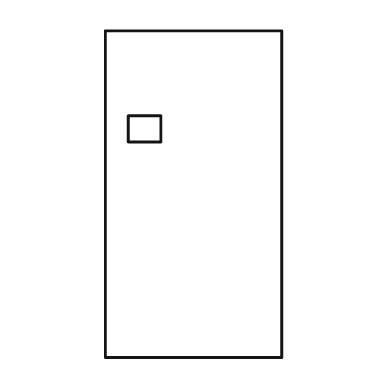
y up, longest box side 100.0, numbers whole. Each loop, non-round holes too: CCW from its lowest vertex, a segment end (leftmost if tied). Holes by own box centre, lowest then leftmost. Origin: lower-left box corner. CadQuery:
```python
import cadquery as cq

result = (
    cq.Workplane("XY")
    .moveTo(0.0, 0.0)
    .lineTo(54.0, 0.0)
    .lineTo(54.0, 100.0)
    .lineTo(0.0, 100.0)
    .close()
    .moveTo(7.0, 66.0)
    .lineTo(17.0, 66.0)
    .lineTo(17.0, 74.0)
    .lineTo(7.0, 74.0)
    .close()
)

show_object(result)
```